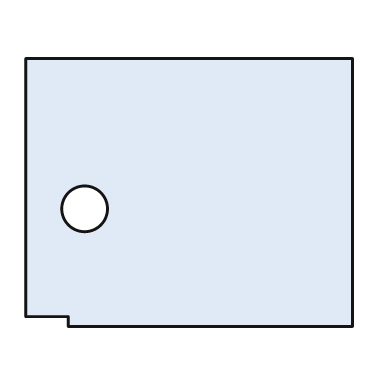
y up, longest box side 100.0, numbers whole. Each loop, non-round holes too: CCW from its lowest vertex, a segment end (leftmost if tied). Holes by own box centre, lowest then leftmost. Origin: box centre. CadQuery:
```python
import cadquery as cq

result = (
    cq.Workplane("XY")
    .moveTo(-37.0, -41.0)
    .lineTo(50.0, -41.0)
    .lineTo(50.0, 41.0)
    .lineTo(-50.0, 41.0)
    .lineTo(-50.0, -38.0)
    .lineTo(-37.0, -38.0)
    .close()
    .moveTo(-32.0, -5.0)
    .circle(7.0)
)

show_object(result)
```